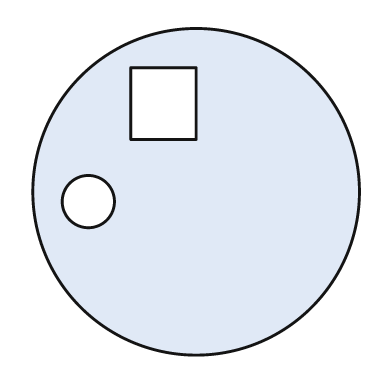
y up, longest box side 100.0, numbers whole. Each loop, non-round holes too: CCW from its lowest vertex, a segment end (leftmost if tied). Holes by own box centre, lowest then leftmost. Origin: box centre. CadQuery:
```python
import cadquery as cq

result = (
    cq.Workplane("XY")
    .moveTo(0.0, 0.0)
    .circle(50.0)
    .moveTo(-33.0, -3.0)
    .circle(8.0)
    .moveTo(-20.0, 16.0)
    .lineTo(0.0, 16.0)
    .lineTo(0.0, 38.0)
    .lineTo(-20.0, 38.0)
    .close()
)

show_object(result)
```